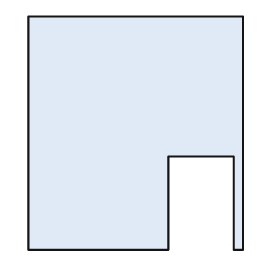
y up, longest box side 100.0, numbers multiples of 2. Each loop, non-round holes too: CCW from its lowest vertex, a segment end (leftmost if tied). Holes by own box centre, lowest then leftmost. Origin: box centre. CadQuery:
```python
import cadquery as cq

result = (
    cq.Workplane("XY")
    .moveTo(-46.0, -50.0)
    .lineTo(14.0, -50.0)
    .lineTo(14.0, -10.0)
    .lineTo(42.0, -10.0)
    .lineTo(42.0, -50.0)
    .lineTo(46.0, -50.0)
    .lineTo(46.0, 50.0)
    .lineTo(-46.0, 50.0)
    .close()
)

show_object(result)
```